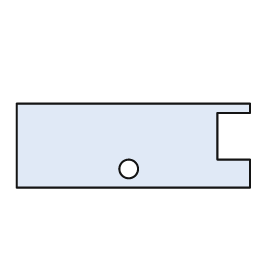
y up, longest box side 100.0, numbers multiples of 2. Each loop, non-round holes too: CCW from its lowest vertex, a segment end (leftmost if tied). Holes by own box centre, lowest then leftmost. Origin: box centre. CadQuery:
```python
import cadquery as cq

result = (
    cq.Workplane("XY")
    .moveTo(-50.0, -18.0)
    .lineTo(50.0, -18.0)
    .lineTo(50.0, -6.0)
    .lineTo(36.0, -6.0)
    .lineTo(36.0, 14.0)
    .lineTo(50.0, 14.0)
    .lineTo(50.0, 18.0)
    .lineTo(-50.0, 18.0)
    .close()
    .moveTo(-2.0, -10.0)
    .circle(4.0)
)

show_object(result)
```